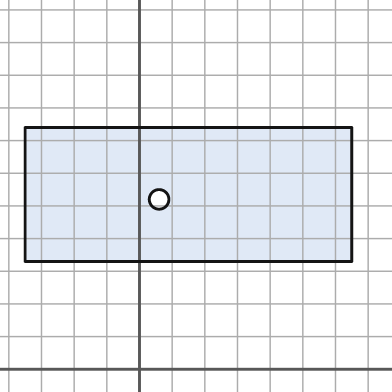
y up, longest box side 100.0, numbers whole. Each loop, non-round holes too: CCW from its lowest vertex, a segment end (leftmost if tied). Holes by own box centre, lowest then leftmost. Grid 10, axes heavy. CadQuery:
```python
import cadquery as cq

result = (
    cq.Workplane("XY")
    .moveTo(-35.0, 33.0)
    .lineTo(65.0, 33.0)
    .lineTo(65.0, 74.0)
    .lineTo(-35.0, 74.0)
    .close()
    .moveTo(6.0, 52.0)
    .circle(3.0)
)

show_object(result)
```